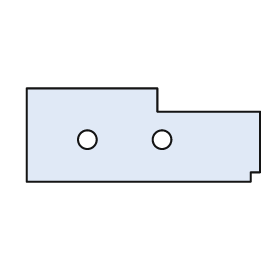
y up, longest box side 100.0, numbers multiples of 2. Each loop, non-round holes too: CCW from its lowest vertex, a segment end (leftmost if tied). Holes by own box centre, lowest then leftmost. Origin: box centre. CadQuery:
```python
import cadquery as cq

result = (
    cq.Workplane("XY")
    .moveTo(-50.0, -20.0)
    .lineTo(46.0, -20.0)
    .lineTo(46.0, -16.0)
    .lineTo(50.0, -16.0)
    .lineTo(50.0, 10.0)
    .lineTo(6.0, 10.0)
    .lineTo(6.0, 20.0)
    .lineTo(-50.0, 20.0)
    .close()
    .moveTo(-24.0, -2.0)
    .circle(4.0)
    .moveTo(8.0, -2.0)
    .circle(4.0)
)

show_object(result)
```